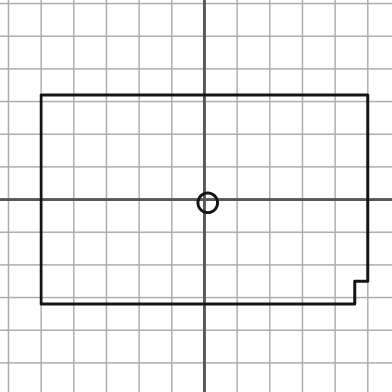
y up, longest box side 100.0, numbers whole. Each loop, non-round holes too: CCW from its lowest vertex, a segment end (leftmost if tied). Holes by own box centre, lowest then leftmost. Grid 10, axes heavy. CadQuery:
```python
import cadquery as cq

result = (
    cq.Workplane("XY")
    .moveTo(-50.0, -32.0)
    .lineTo(46.0, -32.0)
    .lineTo(46.0, -25.0)
    .lineTo(50.0, -25.0)
    .lineTo(50.0, 32.0)
    .lineTo(-50.0, 32.0)
    .close()
    .moveTo(1.0, -1.0)
    .circle(3.0)
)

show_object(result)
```